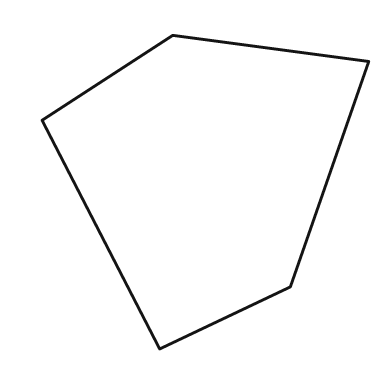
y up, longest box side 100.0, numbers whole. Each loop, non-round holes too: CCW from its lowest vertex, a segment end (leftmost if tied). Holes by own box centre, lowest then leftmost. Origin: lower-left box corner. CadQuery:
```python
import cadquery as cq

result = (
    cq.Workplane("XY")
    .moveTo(36.0, 0.0)
    .lineTo(76.0, 19.0)
    .lineTo(100.0, 88.0)
    .lineTo(40.0, 96.0)
    .lineTo(0.0, 70.0)
    .close()
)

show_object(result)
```